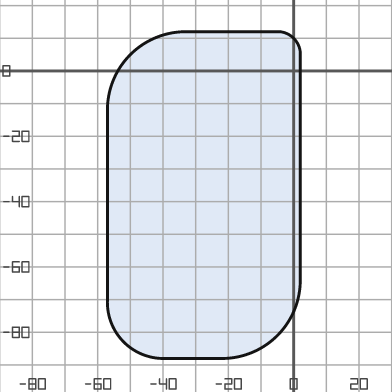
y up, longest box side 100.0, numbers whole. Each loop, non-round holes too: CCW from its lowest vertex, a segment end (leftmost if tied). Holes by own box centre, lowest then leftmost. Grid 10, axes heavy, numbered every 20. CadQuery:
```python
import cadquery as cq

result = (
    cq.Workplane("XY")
    .moveTo(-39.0, -88.0)
    .lineTo(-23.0, -88.0)
    .threePointArc((-5.0, -81.0), (2.0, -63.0))
    .lineTo(2.0, 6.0)
    .threePointArc((0.0, 10.0), (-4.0, 12.0))
    .lineTo(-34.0, 12.0)
    .threePointArc((-50.0, 5.0), (-57.0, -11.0))
    .lineTo(-57.0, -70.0)
    .threePointArc((-52.0, -83.0), (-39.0, -88.0))
    .close()
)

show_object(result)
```